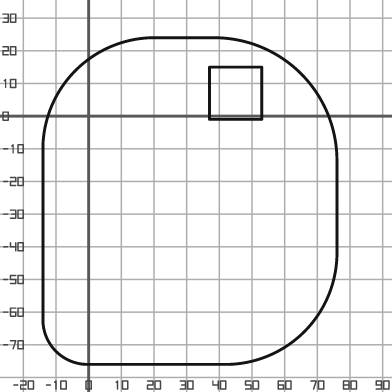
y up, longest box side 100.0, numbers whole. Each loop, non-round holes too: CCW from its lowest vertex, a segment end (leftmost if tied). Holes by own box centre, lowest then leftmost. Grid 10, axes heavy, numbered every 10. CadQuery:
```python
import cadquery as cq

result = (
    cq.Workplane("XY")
    .moveTo(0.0, -76.0)
    .lineTo(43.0, -76.0)
    .threePointArc((66.0, -66.0), (76.0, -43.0))
    .lineTo(76.0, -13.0)
    .threePointArc((65.0, 13.0), (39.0, 24.0))
    .lineTo(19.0, 24.0)
    .threePointArc((-4.0, 14.0), (-14.0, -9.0))
    .lineTo(-14.0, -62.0)
    .threePointArc((-10.0, -72.0), (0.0, -76.0))
    .close()
    .moveTo(37.0, -1.0)
    .lineTo(53.0, -1.0)
    .lineTo(53.0, 15.0)
    .lineTo(37.0, 15.0)
    .close()
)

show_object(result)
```